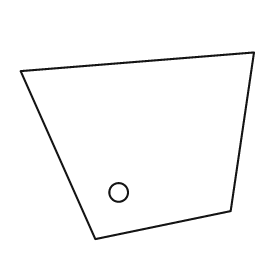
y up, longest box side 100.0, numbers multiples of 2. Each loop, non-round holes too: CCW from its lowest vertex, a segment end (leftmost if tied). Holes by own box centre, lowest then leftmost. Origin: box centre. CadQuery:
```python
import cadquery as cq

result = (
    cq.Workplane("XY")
    .moveTo(-18.0, -40.0)
    .lineTo(40.0, -28.0)
    .lineTo(50.0, 40.0)
    .lineTo(-50.0, 32.0)
    .close()
    .moveTo(-8.0, -20.0)
    .circle(4.0)
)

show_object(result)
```